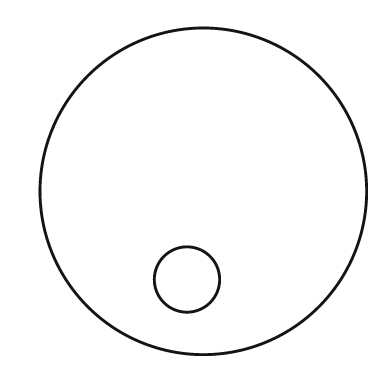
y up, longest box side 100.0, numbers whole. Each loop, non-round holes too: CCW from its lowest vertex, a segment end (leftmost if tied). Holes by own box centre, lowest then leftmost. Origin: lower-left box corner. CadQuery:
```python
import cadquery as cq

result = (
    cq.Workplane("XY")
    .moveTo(50.0, 50.0)
    .circle(50.0)
    .moveTo(45.0, 23.0)
    .circle(10.0)
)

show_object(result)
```